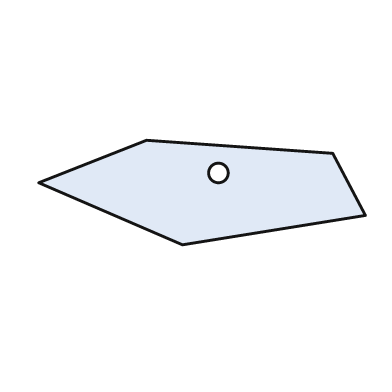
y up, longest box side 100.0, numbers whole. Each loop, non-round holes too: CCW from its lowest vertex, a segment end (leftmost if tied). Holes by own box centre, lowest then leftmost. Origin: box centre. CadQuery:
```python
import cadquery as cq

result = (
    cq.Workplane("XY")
    .moveTo(-6.0, -16.0)
    .lineTo(50.0, -7.0)
    .lineTo(40.0, 12.0)
    .lineTo(-17.0, 16.0)
    .lineTo(-50.0, 3.0)
    .close()
    .moveTo(5.0, 6.0)
    .circle(3.0)
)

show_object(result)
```